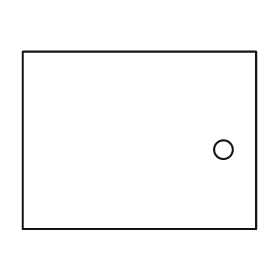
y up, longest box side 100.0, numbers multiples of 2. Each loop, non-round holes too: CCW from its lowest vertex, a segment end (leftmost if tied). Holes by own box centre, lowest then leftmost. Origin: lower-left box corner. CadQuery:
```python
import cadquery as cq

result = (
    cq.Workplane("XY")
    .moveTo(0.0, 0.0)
    .lineTo(100.0, 0.0)
    .lineTo(100.0, 76.0)
    .lineTo(0.0, 76.0)
    .close()
    .moveTo(86.0, 34.0)
    .circle(4.0)
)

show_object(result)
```